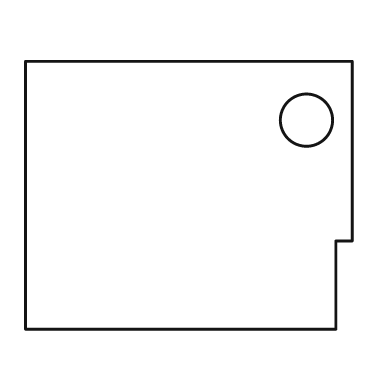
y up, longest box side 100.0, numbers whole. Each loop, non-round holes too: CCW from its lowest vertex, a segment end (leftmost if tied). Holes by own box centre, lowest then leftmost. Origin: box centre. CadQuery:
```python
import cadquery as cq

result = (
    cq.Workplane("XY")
    .moveTo(-50.0, -41.0)
    .lineTo(45.0, -41.0)
    .lineTo(45.0, -14.0)
    .lineTo(50.0, -14.0)
    .lineTo(50.0, 41.0)
    .lineTo(-50.0, 41.0)
    .close()
    .moveTo(36.0, 23.0)
    .circle(8.0)
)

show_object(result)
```